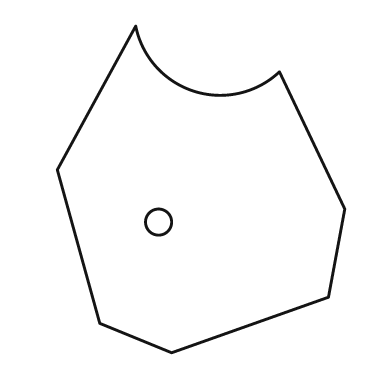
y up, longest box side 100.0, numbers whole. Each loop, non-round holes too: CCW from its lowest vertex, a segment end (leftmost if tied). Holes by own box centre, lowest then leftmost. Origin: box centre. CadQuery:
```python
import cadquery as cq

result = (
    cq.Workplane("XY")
    .moveTo(-9.0, -50.0)
    .lineTo(39.0, -33.0)
    .lineTo(44.0, -6.0)
    .lineTo(24.0, 36.0)
    .threePointArc((-2.0, 30.0), (-20.0, 50.0))
    .lineTo(-44.0, 6.0)
    .lineTo(-31.0, -41.0)
    .close()
    .moveTo(-13.0, -10.0)
    .circle(4.0)
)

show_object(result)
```